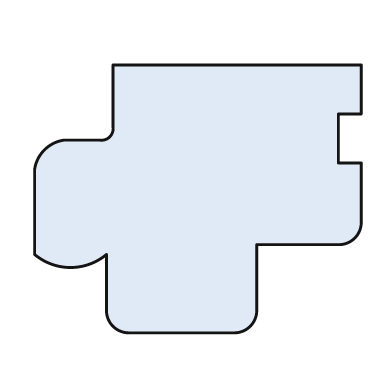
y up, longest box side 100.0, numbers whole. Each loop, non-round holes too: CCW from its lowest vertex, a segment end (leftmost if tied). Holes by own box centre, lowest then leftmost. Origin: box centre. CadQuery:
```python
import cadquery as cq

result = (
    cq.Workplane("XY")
    .moveTo(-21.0, -41.0)
    .lineTo(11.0, -41.0)
    .threePointArc((16.0, -39.0), (18.0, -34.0))
    .lineTo(18.0, -14.0)
    .lineTo(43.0, -14.0)
    .threePointArc((48.0, -12.0), (50.0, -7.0))
    .lineTo(50.0, 11.0)
    .lineTo(43.0, 11.0)
    .lineTo(43.0, 26.0)
    .lineTo(50.0, 26.0)
    .lineTo(50.0, 41.0)
    .lineTo(-26.0, 41.0)
    .lineTo(-26.0, 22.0)
    .threePointArc((-27.0, 19.0), (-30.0, 18.0))
    .lineTo(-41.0, 18.0)
    .threePointArc((-47.0, 15.0), (-50.0, 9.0))
    .lineTo(-50.0, -17.0)
    .threePointArc((-39.0, -21.0), (-28.0, -17.0))
    .lineTo(-28.0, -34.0)
    .threePointArc((-26.0, -39.0), (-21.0, -41.0))
    .close()
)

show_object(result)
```